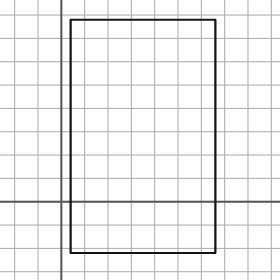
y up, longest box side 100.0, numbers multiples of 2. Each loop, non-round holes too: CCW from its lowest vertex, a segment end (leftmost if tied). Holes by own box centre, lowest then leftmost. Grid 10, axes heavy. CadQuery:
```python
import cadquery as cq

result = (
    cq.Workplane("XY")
    .moveTo(4.0, -22.0)
    .lineTo(66.0, -22.0)
    .lineTo(66.0, 78.0)
    .lineTo(4.0, 78.0)
    .close()
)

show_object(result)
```